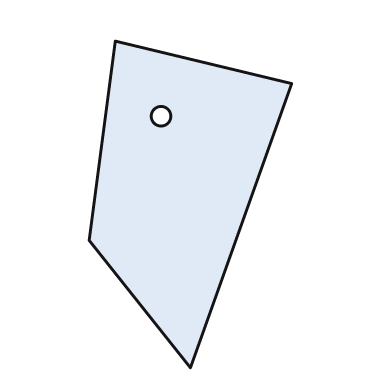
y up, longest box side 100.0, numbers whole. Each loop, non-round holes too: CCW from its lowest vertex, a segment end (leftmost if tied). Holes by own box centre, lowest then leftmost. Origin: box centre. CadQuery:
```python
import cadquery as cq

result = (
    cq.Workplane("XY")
    .moveTo(0.0, -50.0)
    .lineTo(31.0, 37.0)
    .lineTo(-23.0, 50.0)
    .lineTo(-31.0, -11.0)
    .close()
    .moveTo(-9.0, 27.0)
    .circle(3.0)
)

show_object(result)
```